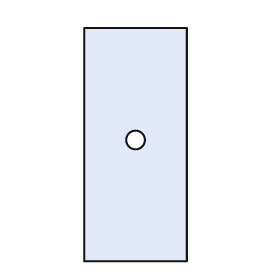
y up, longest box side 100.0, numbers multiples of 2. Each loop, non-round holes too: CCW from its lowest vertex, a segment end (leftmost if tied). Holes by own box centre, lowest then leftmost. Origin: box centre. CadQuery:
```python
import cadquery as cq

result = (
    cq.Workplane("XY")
    .moveTo(-22.0, -50.0)
    .lineTo(22.0, -50.0)
    .lineTo(22.0, 50.0)
    .lineTo(-22.0, 50.0)
    .close()
    .moveTo(0.0, 2.0)
    .circle(4.0)
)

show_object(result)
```